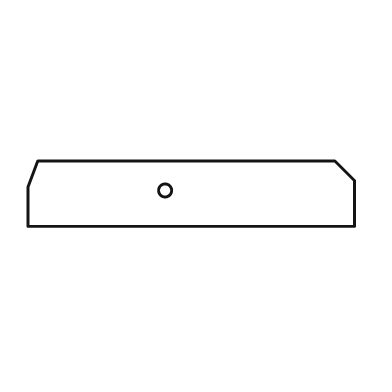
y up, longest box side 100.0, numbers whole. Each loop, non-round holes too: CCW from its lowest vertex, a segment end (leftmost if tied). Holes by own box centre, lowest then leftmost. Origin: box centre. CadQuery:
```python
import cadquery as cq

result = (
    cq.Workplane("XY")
    .moveTo(-50.0, -10.0)
    .lineTo(50.0, -10.0)
    .lineTo(50.0, 4.0)
    .lineTo(44.0, 10.0)
    .lineTo(-47.0, 10.0)
    .lineTo(-50.0, 2.0)
    .close()
    .moveTo(-8.0, 1.0)
    .circle(2.0)
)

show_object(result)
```